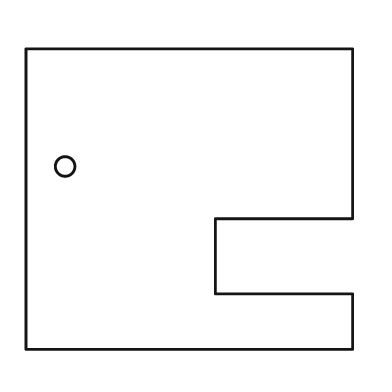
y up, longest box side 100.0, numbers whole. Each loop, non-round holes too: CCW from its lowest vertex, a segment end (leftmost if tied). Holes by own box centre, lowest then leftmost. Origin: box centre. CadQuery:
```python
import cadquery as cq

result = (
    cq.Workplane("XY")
    .moveTo(-50.0, -46.0)
    .lineTo(50.0, -46.0)
    .lineTo(50.0, -29.0)
    .lineTo(8.0, -29.0)
    .lineTo(8.0, -6.0)
    .lineTo(50.0, -6.0)
    .lineTo(50.0, 46.0)
    .lineTo(-50.0, 46.0)
    .close()
    .moveTo(-38.0, 10.0)
    .circle(3.0)
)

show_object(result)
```